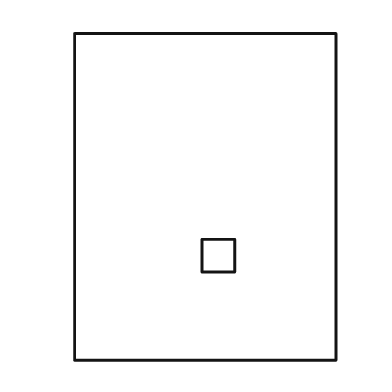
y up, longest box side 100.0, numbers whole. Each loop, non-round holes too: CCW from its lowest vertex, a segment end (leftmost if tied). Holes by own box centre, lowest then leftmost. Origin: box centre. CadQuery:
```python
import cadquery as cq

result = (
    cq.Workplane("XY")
    .moveTo(-40.0, -50.0)
    .lineTo(40.0, -50.0)
    .lineTo(40.0, 50.0)
    .lineTo(-40.0, 50.0)
    .close()
    .moveTo(-1.0, -23.0)
    .lineTo(9.0, -23.0)
    .lineTo(9.0, -13.0)
    .lineTo(-1.0, -13.0)
    .close()
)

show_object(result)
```